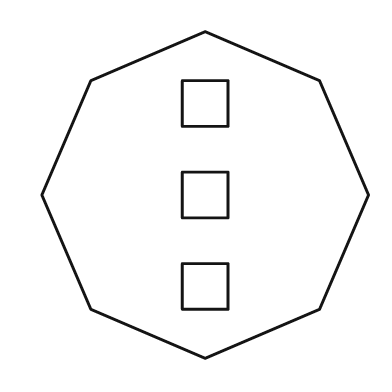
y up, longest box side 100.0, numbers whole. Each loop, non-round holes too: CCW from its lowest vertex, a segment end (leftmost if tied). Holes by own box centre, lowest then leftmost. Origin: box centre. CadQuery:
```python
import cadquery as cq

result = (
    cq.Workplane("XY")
    .moveTo(0.0, -50.0)
    .lineTo(35.0, -35.0)
    .lineTo(50.0, 0.0)
    .lineTo(35.0, 35.0)
    .lineTo(0.0, 50.0)
    .lineTo(-35.0, 35.0)
    .lineTo(-50.0, 0.0)
    .lineTo(-35.0, -35.0)
    .close()
    .moveTo(-7.0, -35.0)
    .lineTo(7.0, -35.0)
    .lineTo(7.0, -21.0)
    .lineTo(-7.0, -21.0)
    .close()
    .moveTo(-7.0, -7.0)
    .lineTo(7.0, -7.0)
    .lineTo(7.0, 7.0)
    .lineTo(-7.0, 7.0)
    .close()
    .moveTo(-7.0, 21.0)
    .lineTo(7.0, 21.0)
    .lineTo(7.0, 35.0)
    .lineTo(-7.0, 35.0)
    .close()
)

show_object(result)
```